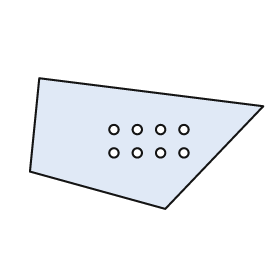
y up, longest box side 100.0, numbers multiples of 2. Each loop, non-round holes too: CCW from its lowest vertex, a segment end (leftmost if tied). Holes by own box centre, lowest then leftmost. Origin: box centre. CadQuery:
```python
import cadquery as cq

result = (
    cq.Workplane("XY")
    .moveTo(8.0, -28.0)
    .lineTo(50.0, 16.0)
    .lineTo(-46.0, 28.0)
    .lineTo(-50.0, -12.0)
    .close()
    .moveTo(-14.0, -4.0)
    .circle(2.0)
    .moveTo(-4.0, -4.0)
    .circle(2.0)
    .moveTo(6.0, -4.0)
    .circle(2.0)
    .moveTo(16.0, -4.0)
    .circle(2.0)
    .moveTo(-14.0, 6.0)
    .circle(2.0)
    .moveTo(-4.0, 6.0)
    .circle(2.0)
    .moveTo(6.0, 6.0)
    .circle(2.0)
    .moveTo(16.0, 6.0)
    .circle(2.0)
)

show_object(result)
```